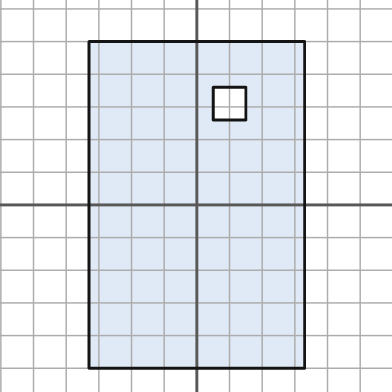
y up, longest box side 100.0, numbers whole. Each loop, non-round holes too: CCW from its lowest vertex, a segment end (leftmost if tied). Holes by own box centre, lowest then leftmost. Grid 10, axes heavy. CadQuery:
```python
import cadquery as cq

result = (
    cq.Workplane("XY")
    .moveTo(-33.0, -50.0)
    .lineTo(33.0, -50.0)
    .lineTo(33.0, 50.0)
    .lineTo(-33.0, 50.0)
    .close()
    .moveTo(5.0, 26.0)
    .lineTo(15.0, 26.0)
    .lineTo(15.0, 36.0)
    .lineTo(5.0, 36.0)
    .close()
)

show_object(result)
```